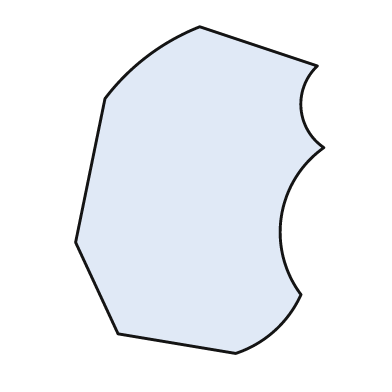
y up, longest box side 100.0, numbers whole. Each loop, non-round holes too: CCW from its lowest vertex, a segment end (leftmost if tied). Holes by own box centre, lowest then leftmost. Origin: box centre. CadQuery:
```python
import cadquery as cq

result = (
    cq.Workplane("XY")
    .moveTo(11.0, -50.0)
    .threePointArc((23.0, -43.0), (31.0, -32.0))
    .threePointArc((25.0, -8.0), (38.0, 13.0))
    .threePointArc((31.0, 25.0), (36.0, 38.0))
    .lineTo(0.0, 50.0)
    .threePointArc((-16.0, 41.0), (-29.0, 28.0))
    .lineTo(-38.0, -16.0)
    .lineTo(-25.0, -44.0)
    .close()
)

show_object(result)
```